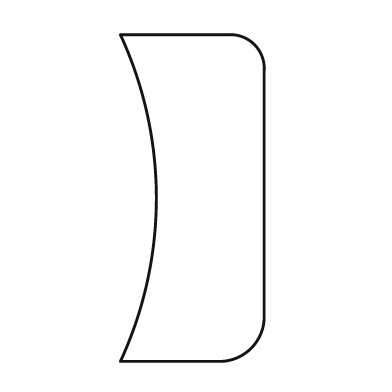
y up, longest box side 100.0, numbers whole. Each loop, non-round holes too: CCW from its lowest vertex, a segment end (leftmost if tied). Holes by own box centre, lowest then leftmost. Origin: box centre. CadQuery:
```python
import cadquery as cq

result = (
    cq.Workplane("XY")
    .moveTo(-22.0, -50.0)
    .lineTo(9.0, -50.0)
    .threePointArc((18.0, -46.0), (22.0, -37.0))
    .lineTo(22.0, 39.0)
    .threePointArc((19.0, 47.0), (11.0, 50.0))
    .lineTo(-22.0, 50.0)
    .threePointArc((-11.0, 0.0), (-22.0, -50.0))
    .close()
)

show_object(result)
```